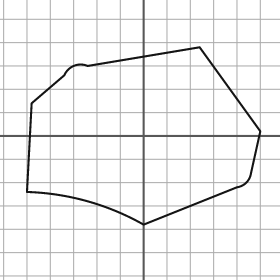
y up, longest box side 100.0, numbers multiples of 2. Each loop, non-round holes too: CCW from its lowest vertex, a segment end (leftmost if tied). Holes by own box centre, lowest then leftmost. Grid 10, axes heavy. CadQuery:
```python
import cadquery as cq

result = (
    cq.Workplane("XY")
    .moveTo(0.0, -38.0)
    .lineTo(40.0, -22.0)
    .threePointArc((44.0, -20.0), (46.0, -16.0))
    .lineTo(50.0, 2.0)
    .lineTo(24.0, 38.0)
    .lineTo(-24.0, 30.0)
    .threePointArc((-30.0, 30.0), (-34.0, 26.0))
    .lineTo(-48.0, 14.0)
    .lineTo(-50.0, -24.0)
    .threePointArc((-24.0, -28.0), (0.0, -38.0))
    .close()
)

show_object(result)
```